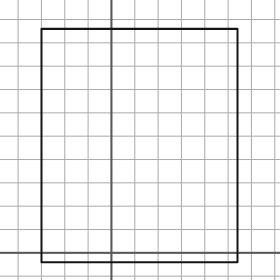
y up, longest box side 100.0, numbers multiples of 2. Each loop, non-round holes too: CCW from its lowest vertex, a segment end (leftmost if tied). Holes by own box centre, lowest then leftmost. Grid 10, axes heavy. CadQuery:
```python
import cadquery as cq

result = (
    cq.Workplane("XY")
    .moveTo(-30.0, -4.0)
    .lineTo(54.0, -4.0)
    .lineTo(54.0, 96.0)
    .lineTo(-30.0, 96.0)
    .close()
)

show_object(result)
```